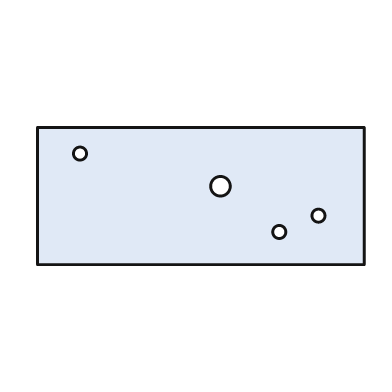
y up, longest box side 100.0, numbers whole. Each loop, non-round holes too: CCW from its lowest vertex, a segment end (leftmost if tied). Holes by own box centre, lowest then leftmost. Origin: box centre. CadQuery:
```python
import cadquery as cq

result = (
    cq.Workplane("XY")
    .moveTo(-50.0, -21.0)
    .lineTo(50.0, -21.0)
    .lineTo(50.0, 21.0)
    .lineTo(-50.0, 21.0)
    .close()
    .moveTo(24.0, -11.0)
    .circle(2.0)
    .moveTo(36.0, -6.0)
    .circle(2.0)
    .moveTo(6.0, 3.0)
    .circle(3.0)
    .moveTo(-37.0, 13.0)
    .circle(2.0)
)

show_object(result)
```